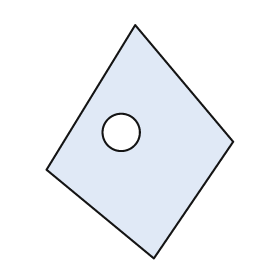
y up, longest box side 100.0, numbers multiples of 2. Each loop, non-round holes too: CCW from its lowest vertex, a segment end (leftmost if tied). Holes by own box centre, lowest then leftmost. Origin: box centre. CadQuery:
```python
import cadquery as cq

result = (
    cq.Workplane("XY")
    .moveTo(6.0, -50.0)
    .lineTo(40.0, 0.0)
    .lineTo(-2.0, 50.0)
    .lineTo(-40.0, -12.0)
    .close()
    .moveTo(-8.0, 4.0)
    .circle(8.0)
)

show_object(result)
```